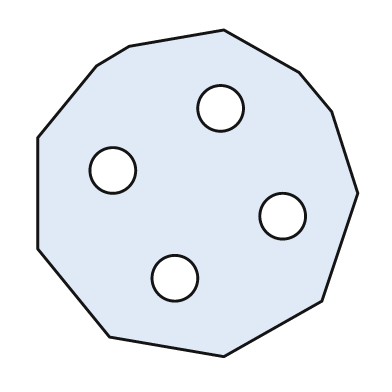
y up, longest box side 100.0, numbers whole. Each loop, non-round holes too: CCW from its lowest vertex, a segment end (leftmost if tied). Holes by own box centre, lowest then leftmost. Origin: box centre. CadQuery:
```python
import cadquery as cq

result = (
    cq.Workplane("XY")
    .moveTo(8.0, -50.0)
    .lineTo(38.0, -33.0)
    .lineTo(49.0, 0.0)
    .lineTo(41.0, 25.0)
    .lineTo(31.0, 37.0)
    .lineTo(8.0, 50.0)
    .lineTo(-21.0, 45.0)
    .lineTo(-31.0, 39.0)
    .lineTo(-49.0, 17.0)
    .lineTo(-49.0, -17.0)
    .lineTo(-27.0, -44.0)
    .close()
    .moveTo(-7.0, -26.0)
    .circle(7.0)
    .moveTo(26.0, -7.0)
    .circle(7.0)
    .moveTo(-26.0, 7.0)
    .circle(7.0)
    .moveTo(7.0, 26.0)
    .circle(7.0)
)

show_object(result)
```